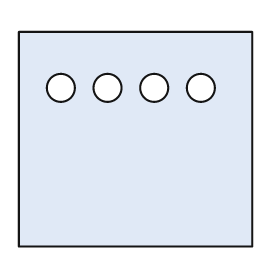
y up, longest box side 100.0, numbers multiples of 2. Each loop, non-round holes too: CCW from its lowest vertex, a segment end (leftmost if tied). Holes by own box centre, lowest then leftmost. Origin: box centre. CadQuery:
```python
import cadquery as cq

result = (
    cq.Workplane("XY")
    .moveTo(-50.0, -46.0)
    .lineTo(50.0, -46.0)
    .lineTo(50.0, 46.0)
    .lineTo(-50.0, 46.0)
    .close()
    .moveTo(-32.0, 22.0)
    .circle(6.0)
    .moveTo(-12.0, 22.0)
    .circle(6.0)
    .moveTo(8.0, 22.0)
    .circle(6.0)
    .moveTo(28.0, 22.0)
    .circle(6.0)
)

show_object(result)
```